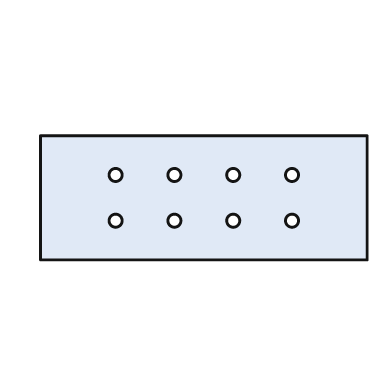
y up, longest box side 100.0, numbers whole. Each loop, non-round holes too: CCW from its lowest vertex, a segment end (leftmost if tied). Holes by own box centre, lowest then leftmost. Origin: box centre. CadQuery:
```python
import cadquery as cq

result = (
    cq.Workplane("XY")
    .moveTo(-50.0, -19.0)
    .lineTo(50.0, -19.0)
    .lineTo(50.0, 19.0)
    .lineTo(-50.0, 19.0)
    .close()
    .moveTo(-27.0, -7.0)
    .circle(2.0)
    .moveTo(-9.0, -7.0)
    .circle(2.0)
    .moveTo(9.0, -7.0)
    .circle(2.0)
    .moveTo(27.0, -7.0)
    .circle(2.0)
    .moveTo(-27.0, 7.0)
    .circle(2.0)
    .moveTo(-9.0, 7.0)
    .circle(2.0)
    .moveTo(9.0, 7.0)
    .circle(2.0)
    .moveTo(27.0, 7.0)
    .circle(2.0)
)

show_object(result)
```